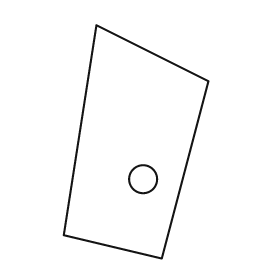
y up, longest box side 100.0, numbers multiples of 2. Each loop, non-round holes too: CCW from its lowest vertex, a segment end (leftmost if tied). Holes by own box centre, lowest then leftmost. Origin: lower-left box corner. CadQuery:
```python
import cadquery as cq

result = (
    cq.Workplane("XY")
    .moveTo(42.0, 0.0)
    .lineTo(62.0, 76.0)
    .lineTo(14.0, 100.0)
    .lineTo(0.0, 10.0)
    .close()
    .moveTo(34.0, 34.0)
    .circle(6.0)
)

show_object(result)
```